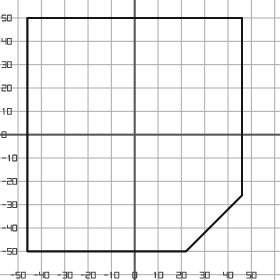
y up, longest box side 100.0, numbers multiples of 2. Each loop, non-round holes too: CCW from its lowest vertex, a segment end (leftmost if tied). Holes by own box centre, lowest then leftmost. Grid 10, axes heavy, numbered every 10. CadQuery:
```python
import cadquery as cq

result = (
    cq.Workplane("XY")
    .moveTo(-46.0, -50.0)
    .lineTo(22.0, -50.0)
    .lineTo(46.0, -26.0)
    .lineTo(46.0, 50.0)
    .lineTo(-46.0, 50.0)
    .close()
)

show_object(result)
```